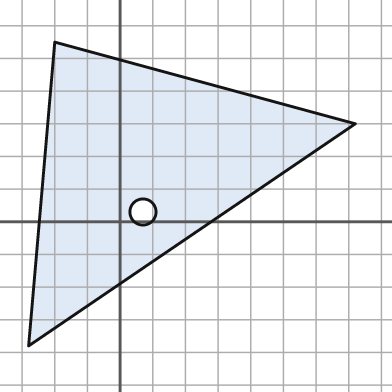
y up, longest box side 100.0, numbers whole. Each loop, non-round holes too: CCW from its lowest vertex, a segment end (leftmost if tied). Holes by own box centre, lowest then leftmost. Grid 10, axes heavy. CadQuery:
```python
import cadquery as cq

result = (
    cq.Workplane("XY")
    .moveTo(-28.0, -38.0)
    .lineTo(72.0, 30.0)
    .lineTo(-20.0, 55.0)
    .close()
    .moveTo(7.0, 3.0)
    .circle(4.0)
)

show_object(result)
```